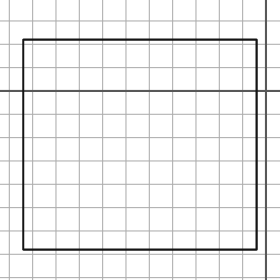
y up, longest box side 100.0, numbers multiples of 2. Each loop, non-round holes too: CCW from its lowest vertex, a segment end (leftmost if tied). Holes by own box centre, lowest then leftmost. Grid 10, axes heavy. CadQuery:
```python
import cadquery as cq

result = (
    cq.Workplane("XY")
    .moveTo(-104.0, -68.0)
    .lineTo(-4.0, -68.0)
    .lineTo(-4.0, 22.0)
    .lineTo(-104.0, 22.0)
    .close()
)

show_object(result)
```